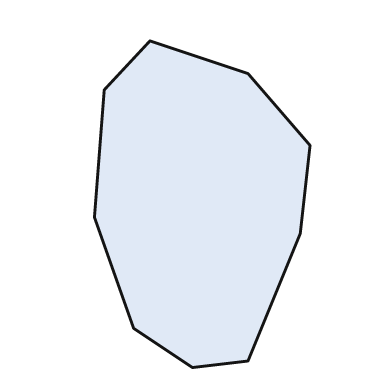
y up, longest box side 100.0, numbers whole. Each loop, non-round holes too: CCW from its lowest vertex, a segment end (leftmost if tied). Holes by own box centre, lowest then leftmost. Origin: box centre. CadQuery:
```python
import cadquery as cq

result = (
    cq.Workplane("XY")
    .moveTo(-3.0, -50.0)
    .lineTo(14.0, -48.0)
    .lineTo(30.0, -9.0)
    .lineTo(33.0, 18.0)
    .lineTo(14.0, 40.0)
    .lineTo(-16.0, 50.0)
    .lineTo(-30.0, 35.0)
    .lineTo(-33.0, -4.0)
    .lineTo(-21.0, -38.0)
    .close()
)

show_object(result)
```